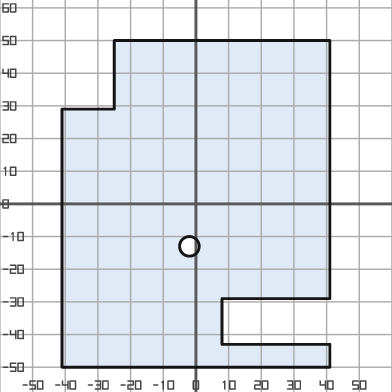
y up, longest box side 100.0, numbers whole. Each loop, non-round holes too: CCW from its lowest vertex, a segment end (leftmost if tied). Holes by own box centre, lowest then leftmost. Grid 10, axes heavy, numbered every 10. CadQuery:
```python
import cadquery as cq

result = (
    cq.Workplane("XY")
    .moveTo(-41.0, -50.0)
    .lineTo(41.0, -50.0)
    .lineTo(41.0, -43.0)
    .lineTo(8.0, -43.0)
    .lineTo(8.0, -29.0)
    .lineTo(41.0, -29.0)
    .lineTo(41.0, 50.0)
    .lineTo(-25.0, 50.0)
    .lineTo(-25.0, 29.0)
    .lineTo(-41.0, 29.0)
    .close()
    .moveTo(-2.0, -13.0)
    .circle(3.0)
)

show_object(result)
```